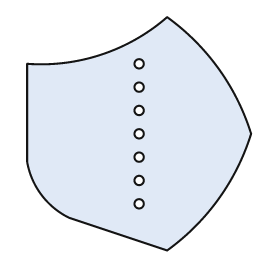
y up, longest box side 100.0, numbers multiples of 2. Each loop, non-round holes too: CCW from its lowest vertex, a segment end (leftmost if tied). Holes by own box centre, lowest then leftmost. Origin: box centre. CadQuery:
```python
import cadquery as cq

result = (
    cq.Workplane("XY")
    .moveTo(12.0, -50.0)
    .threePointArc((34.0, -28.0), (48.0, 0.0))
    .threePointArc((34.0, 28.0), (12.0, 50.0))
    .threePointArc((-16.0, 34.0), (-48.0, 30.0))
    .lineTo(-48.0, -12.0)
    .threePointArc((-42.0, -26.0), (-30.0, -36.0))
    .close()
    .moveTo(0.0, -30.0)
    .circle(2.0)
    .moveTo(0.0, -20.0)
    .circle(2.0)
    .moveTo(0.0, -10.0)
    .circle(2.0)
    .moveTo(0.0, 0.0)
    .circle(2.0)
    .moveTo(0.0, 10.0)
    .circle(2.0)
    .moveTo(0.0, 20.0)
    .circle(2.0)
    .moveTo(0.0, 30.0)
    .circle(2.0)
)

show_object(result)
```